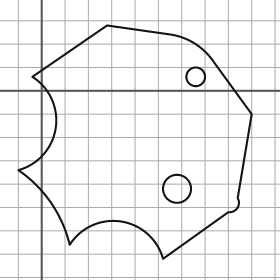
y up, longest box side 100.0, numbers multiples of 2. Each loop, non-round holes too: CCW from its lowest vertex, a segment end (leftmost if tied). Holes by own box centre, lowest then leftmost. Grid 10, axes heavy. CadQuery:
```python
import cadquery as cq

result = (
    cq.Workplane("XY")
    .moveTo(52.0, -72.0)
    .lineTo(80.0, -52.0)
    .threePointArc((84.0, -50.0), (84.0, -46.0))
    .lineTo(90.0, -10.0)
    .lineTo(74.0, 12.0)
    .threePointArc((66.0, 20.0), (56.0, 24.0))
    .lineTo(28.0, 28.0)
    .lineTo(-4.0, 6.0)
    .threePointArc((6.0, -16.0), (-10.0, -34.0))
    .threePointArc((4.0, -48.0), (12.0, -66.0))
    .threePointArc((34.0, -56.0), (52.0, -72.0))
    .close()
    .moveTo(58.0, -42.0)
    .circle(6.0)
    .moveTo(66.0, 6.0)
    .circle(4.0)
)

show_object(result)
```